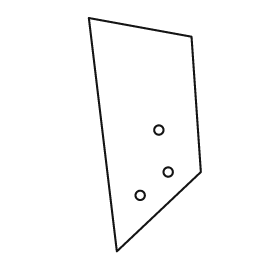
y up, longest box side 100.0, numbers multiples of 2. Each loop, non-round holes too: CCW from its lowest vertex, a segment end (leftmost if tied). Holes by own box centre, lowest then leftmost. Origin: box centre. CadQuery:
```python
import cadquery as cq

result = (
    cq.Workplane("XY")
    .moveTo(-12.0, -50.0)
    .lineTo(24.0, -16.0)
    .lineTo(20.0, 42.0)
    .lineTo(-24.0, 50.0)
    .close()
    .moveTo(-2.0, -26.0)
    .circle(2.0)
    .moveTo(10.0, -16.0)
    .circle(2.0)
    .moveTo(6.0, 2.0)
    .circle(2.0)
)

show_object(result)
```